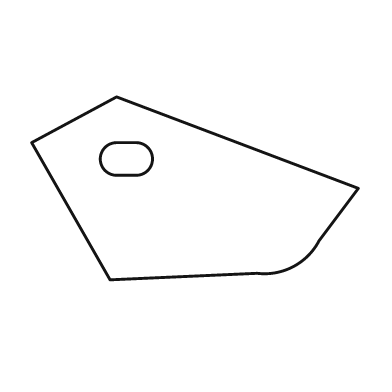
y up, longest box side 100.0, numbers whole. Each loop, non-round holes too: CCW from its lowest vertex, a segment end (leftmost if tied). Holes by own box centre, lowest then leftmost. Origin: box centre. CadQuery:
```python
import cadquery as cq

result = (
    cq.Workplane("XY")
    .moveTo(-26.0, -28.0)
    .lineTo(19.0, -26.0)
    .threePointArc((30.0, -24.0), (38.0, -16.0))
    .lineTo(50.0, 0.0)
    .lineTo(-24.0, 28.0)
    .lineTo(-50.0, 14.0)
    .close()
    .moveTo(-24.0, 4.0)
    .lineTo(-18.0, 4.0)
    .threePointArc((-13.0, 9.0), (-18.0, 14.0))
    .lineTo(-24.0, 14.0)
    .threePointArc((-29.0, 9.0), (-24.0, 4.0))
    .close()
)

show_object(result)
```